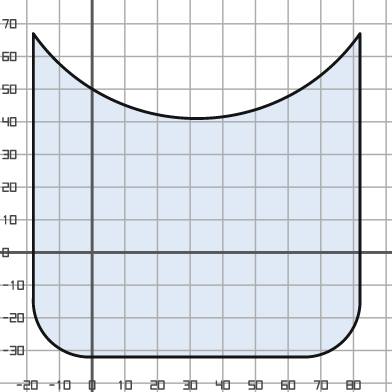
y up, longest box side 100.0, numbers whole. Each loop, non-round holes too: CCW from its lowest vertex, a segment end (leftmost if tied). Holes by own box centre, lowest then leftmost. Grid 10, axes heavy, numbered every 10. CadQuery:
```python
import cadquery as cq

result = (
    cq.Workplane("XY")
    .moveTo(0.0, -32.0)
    .lineTo(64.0, -32.0)
    .threePointArc((77.0, -27.0), (82.0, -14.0))
    .lineTo(82.0, 67.0)
    .threePointArc((32.0, 41.0), (-18.0, 67.0))
    .lineTo(-18.0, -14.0)
    .threePointArc((-13.0, -27.0), (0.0, -32.0))
    .close()
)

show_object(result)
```